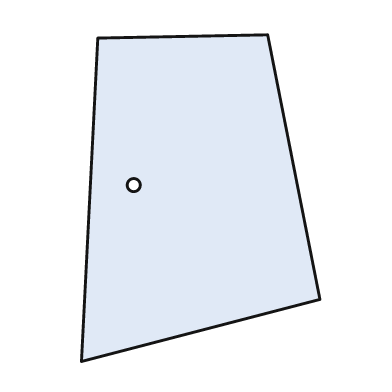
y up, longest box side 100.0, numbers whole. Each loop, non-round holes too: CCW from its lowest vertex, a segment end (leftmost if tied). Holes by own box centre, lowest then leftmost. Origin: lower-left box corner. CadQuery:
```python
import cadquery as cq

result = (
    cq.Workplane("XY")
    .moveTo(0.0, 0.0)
    .lineTo(73.0, 19.0)
    .lineTo(57.0, 100.0)
    .lineTo(5.0, 99.0)
    .close()
    .moveTo(16.0, 54.0)
    .circle(2.0)
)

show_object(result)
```